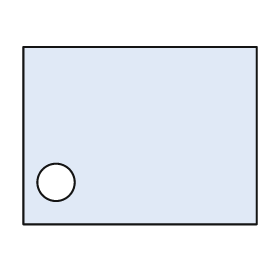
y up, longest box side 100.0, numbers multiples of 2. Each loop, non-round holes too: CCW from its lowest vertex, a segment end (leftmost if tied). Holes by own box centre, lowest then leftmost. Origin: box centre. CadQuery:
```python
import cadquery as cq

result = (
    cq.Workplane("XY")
    .moveTo(-50.0, -38.0)
    .lineTo(50.0, -38.0)
    .lineTo(50.0, 38.0)
    .lineTo(-50.0, 38.0)
    .close()
    .moveTo(-36.0, -20.0)
    .circle(8.0)
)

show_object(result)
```